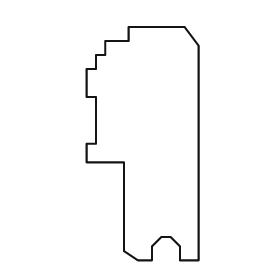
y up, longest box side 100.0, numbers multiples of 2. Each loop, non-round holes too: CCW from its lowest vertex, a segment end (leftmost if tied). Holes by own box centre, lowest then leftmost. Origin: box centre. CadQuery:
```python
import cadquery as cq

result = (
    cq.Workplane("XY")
    .moveTo(-2.0, -50.0)
    .lineTo(4.0, -50.0)
    .lineTo(4.0, -44.0)
    .lineTo(8.0, -40.0)
    .lineTo(12.0, -40.0)
    .lineTo(16.0, -44.0)
    .lineTo(16.0, -50.0)
    .lineTo(24.0, -50.0)
    .lineTo(24.0, 42.0)
    .lineTo(18.0, 50.0)
    .lineTo(-6.0, 50.0)
    .lineTo(-6.0, 44.0)
    .lineTo(-16.0, 44.0)
    .lineTo(-16.0, 38.0)
    .lineTo(-20.0, 38.0)
    .lineTo(-20.0, 32.0)
    .lineTo(-24.0, 32.0)
    .lineTo(-24.0, 20.0)
    .lineTo(-20.0, 20.0)
    .lineTo(-20.0, 0.0)
    .lineTo(-24.0, 0.0)
    .lineTo(-24.0, -8.0)
    .lineTo(-8.0, -8.0)
    .lineTo(-8.0, -46.0)
    .close()
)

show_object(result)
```